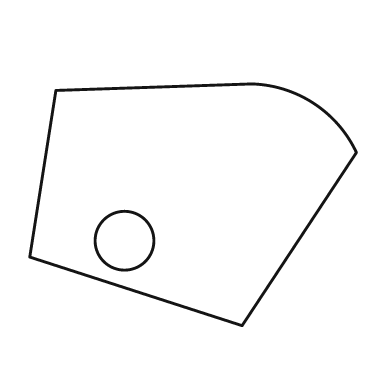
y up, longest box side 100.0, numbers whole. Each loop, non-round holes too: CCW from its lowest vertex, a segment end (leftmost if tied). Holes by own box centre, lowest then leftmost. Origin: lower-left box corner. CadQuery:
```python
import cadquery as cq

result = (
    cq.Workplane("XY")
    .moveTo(65.0, 0.0)
    .lineTo(100.0, 53.0)
    .threePointArc((87.0, 68.0), (68.0, 74.0))
    .lineTo(8.0, 72.0)
    .lineTo(0.0, 21.0)
    .close()
    .moveTo(29.0, 26.0)
    .circle(9.0)
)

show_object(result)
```